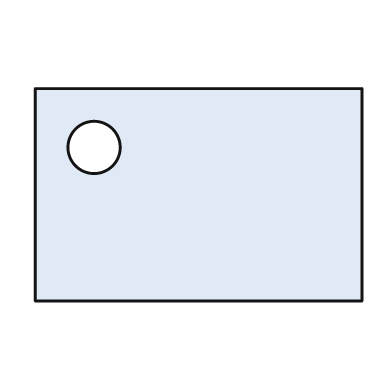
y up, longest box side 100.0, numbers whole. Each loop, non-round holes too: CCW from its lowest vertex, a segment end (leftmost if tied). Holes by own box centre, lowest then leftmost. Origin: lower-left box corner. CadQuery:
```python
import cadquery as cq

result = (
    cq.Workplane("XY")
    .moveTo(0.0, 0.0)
    .lineTo(100.0, 0.0)
    .lineTo(100.0, 65.0)
    .lineTo(0.0, 65.0)
    .close()
    .moveTo(18.0, 47.0)
    .circle(8.0)
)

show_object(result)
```